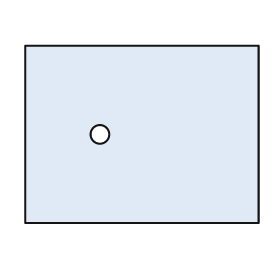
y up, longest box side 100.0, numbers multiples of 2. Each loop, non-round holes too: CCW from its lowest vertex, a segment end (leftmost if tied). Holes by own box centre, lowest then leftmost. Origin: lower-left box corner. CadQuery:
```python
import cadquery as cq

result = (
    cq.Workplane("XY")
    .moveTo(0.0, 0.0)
    .lineTo(100.0, 0.0)
    .lineTo(100.0, 76.0)
    .lineTo(0.0, 76.0)
    .close()
    .moveTo(32.0, 38.0)
    .circle(4.0)
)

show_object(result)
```